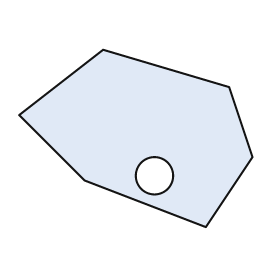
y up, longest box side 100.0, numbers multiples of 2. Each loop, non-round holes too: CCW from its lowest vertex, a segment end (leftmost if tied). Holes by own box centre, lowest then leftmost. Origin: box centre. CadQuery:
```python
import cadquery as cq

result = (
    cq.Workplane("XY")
    .moveTo(30.0, -38.0)
    .lineTo(50.0, -8.0)
    .lineTo(40.0, 22.0)
    .lineTo(-14.0, 38.0)
    .lineTo(-50.0, 10.0)
    .lineTo(-22.0, -18.0)
    .close()
    .moveTo(8.0, -16.0)
    .circle(8.0)
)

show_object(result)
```